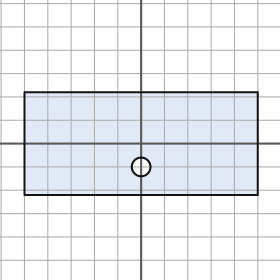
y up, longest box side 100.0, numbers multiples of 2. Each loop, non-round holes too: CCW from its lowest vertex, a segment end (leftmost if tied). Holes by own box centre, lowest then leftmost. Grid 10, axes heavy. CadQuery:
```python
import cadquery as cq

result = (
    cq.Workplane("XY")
    .moveTo(-50.0, -22.0)
    .lineTo(50.0, -22.0)
    .lineTo(50.0, 22.0)
    .lineTo(-50.0, 22.0)
    .close()
    .moveTo(0.0, -10.0)
    .circle(4.0)
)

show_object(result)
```